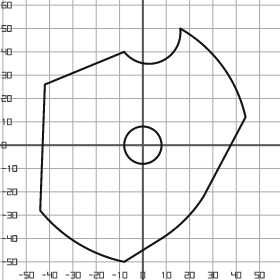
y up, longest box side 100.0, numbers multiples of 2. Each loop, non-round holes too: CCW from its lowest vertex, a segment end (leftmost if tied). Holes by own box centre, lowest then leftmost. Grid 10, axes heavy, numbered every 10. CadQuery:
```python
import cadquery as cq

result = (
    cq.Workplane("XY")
    .moveTo(-8.0, -50.0)
    .lineTo(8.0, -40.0)
    .threePointArc((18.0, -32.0), (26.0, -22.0))
    .lineTo(44.0, 12.0)
    .threePointArc((34.0, 34.0), (16.0, 50.0))
    .threePointArc((8.0, 36.0), (-8.0, 40.0))
    .lineTo(-42.0, 26.0)
    .lineTo(-44.0, -28.0)
    .threePointArc((-28.0, -42.0), (-8.0, -50.0))
    .close()
    .moveTo(0.0, 0.0)
    .circle(8.0)
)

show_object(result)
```